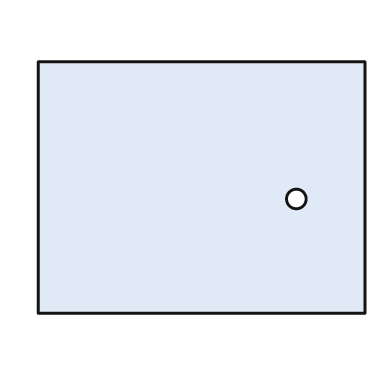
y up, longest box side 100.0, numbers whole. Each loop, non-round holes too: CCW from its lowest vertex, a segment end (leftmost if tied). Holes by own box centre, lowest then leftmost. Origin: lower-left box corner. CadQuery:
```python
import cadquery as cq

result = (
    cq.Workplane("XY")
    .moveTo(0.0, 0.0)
    .lineTo(100.0, 0.0)
    .lineTo(100.0, 77.0)
    .lineTo(0.0, 77.0)
    .close()
    .moveTo(79.0, 35.0)
    .circle(3.0)
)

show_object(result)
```